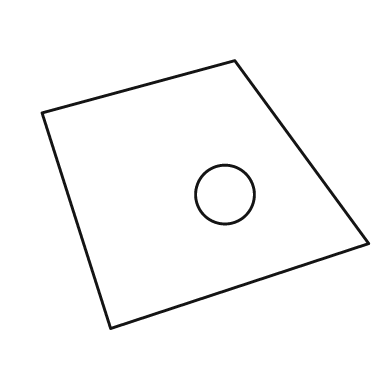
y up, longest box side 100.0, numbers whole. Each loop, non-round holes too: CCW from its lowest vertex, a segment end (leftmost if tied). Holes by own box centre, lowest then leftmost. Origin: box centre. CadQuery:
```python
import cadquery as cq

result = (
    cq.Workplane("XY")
    .moveTo(-29.0, -41.0)
    .lineTo(50.0, -15.0)
    .lineTo(9.0, 41.0)
    .lineTo(-50.0, 25.0)
    .close()
    .moveTo(6.0, 0.0)
    .circle(9.0)
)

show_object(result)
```